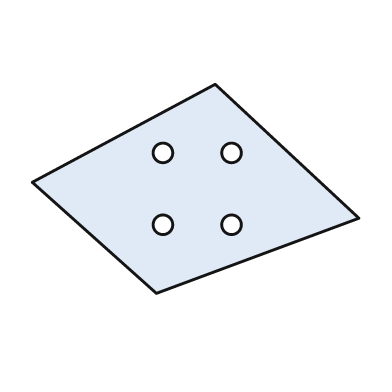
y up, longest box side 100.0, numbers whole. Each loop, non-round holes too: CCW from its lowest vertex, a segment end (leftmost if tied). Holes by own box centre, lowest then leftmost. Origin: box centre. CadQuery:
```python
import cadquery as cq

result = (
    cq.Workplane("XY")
    .moveTo(-12.0, -32.0)
    .lineTo(50.0, -9.0)
    .lineTo(6.0, 32.0)
    .lineTo(-50.0, 2.0)
    .close()
    .moveTo(-10.0, -11.0)
    .circle(3.0)
    .moveTo(11.0, -11.0)
    .circle(3.0)
    .moveTo(-10.0, 11.0)
    .circle(3.0)
    .moveTo(11.0, 11.0)
    .circle(3.0)
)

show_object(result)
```